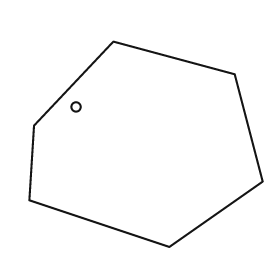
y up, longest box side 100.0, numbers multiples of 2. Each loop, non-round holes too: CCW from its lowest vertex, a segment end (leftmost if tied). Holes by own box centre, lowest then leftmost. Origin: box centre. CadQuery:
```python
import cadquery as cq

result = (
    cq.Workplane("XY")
    .moveTo(10.0, -44.0)
    .lineTo(50.0, -16.0)
    .lineTo(38.0, 30.0)
    .lineTo(-14.0, 44.0)
    .lineTo(-48.0, 8.0)
    .lineTo(-50.0, -24.0)
    .close()
    .moveTo(-30.0, 16.0)
    .circle(2.0)
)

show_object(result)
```